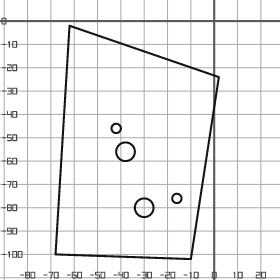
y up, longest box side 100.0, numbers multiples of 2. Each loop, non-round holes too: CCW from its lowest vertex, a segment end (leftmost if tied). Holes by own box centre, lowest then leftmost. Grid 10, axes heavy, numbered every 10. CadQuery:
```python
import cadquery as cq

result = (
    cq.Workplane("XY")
    .moveTo(-10.0, -102.0)
    .lineTo(2.0, -24.0)
    .lineTo(-62.0, -2.0)
    .lineTo(-68.0, -100.0)
    .close()
    .moveTo(-30.0, -80.0)
    .circle(4.0)
    .moveTo(-16.0, -76.0)
    .circle(2.0)
    .moveTo(-38.0, -56.0)
    .circle(4.0)
    .moveTo(-42.0, -46.0)
    .circle(2.0)
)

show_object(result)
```